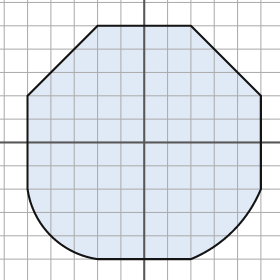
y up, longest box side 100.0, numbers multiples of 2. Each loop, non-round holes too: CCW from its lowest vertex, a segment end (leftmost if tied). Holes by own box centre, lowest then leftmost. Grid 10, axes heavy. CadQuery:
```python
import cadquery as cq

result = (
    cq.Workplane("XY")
    .moveTo(-20.0, -50.0)
    .lineTo(20.0, -50.0)
    .threePointArc((38.0, -38.0), (50.0, -20.0))
    .lineTo(50.0, 20.0)
    .lineTo(20.0, 50.0)
    .lineTo(-20.0, 50.0)
    .lineTo(-50.0, 20.0)
    .lineTo(-50.0, -20.0)
    .threePointArc((-40.0, -40.0), (-20.0, -50.0))
    .close()
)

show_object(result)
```